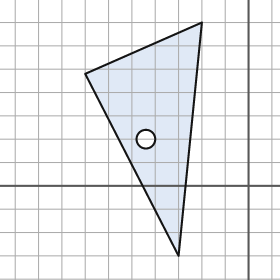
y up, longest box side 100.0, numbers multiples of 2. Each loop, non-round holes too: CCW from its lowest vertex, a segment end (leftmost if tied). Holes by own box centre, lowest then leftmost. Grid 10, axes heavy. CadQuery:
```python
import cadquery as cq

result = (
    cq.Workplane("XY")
    .moveTo(-30.0, -30.0)
    .lineTo(-20.0, 70.0)
    .lineTo(-70.0, 48.0)
    .close()
    .moveTo(-44.0, 20.0)
    .circle(4.0)
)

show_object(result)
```